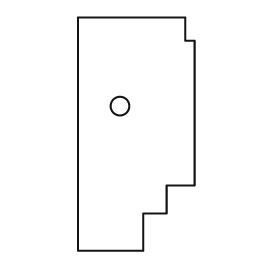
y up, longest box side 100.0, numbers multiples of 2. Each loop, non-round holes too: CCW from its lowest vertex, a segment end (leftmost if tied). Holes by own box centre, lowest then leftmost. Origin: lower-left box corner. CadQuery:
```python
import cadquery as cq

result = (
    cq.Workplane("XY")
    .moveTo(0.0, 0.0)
    .lineTo(28.0, 0.0)
    .lineTo(28.0, 16.0)
    .lineTo(38.0, 16.0)
    .lineTo(38.0, 28.0)
    .lineTo(50.0, 28.0)
    .lineTo(50.0, 90.0)
    .lineTo(46.0, 90.0)
    .lineTo(46.0, 100.0)
    .lineTo(0.0, 100.0)
    .close()
    .moveTo(18.0, 62.0)
    .circle(4.0)
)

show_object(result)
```